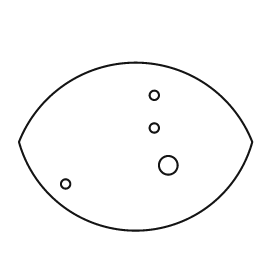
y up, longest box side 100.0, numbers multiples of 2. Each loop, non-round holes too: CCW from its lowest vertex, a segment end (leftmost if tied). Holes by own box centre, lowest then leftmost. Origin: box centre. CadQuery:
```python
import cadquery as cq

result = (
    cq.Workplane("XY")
    .moveTo(-50.0, 2.0)
    .threePointArc((0.0, -36.0), (50.0, 2.0))
    .threePointArc((0.0, 36.0), (-50.0, 2.0))
    .close()
    .moveTo(-30.0, -16.0)
    .circle(2.0)
    .moveTo(14.0, -8.0)
    .circle(4.0)
    .moveTo(8.0, 8.0)
    .circle(2.0)
    .moveTo(8.0, 22.0)
    .circle(2.0)
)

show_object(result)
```